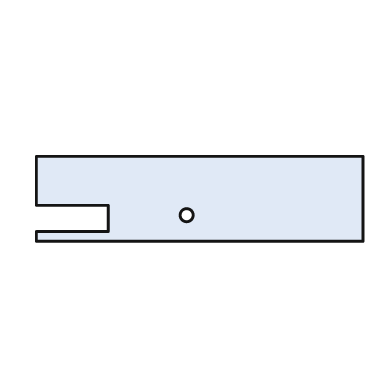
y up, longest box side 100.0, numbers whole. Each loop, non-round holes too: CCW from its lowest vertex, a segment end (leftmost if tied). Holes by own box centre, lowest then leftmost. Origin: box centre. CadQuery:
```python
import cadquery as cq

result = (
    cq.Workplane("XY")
    .moveTo(-50.0, -13.0)
    .lineTo(50.0, -13.0)
    .lineTo(50.0, 13.0)
    .lineTo(-50.0, 13.0)
    .lineTo(-50.0, -2.0)
    .lineTo(-28.0, -2.0)
    .lineTo(-28.0, -10.0)
    .lineTo(-50.0, -10.0)
    .close()
    .moveTo(-4.0, -5.0)
    .circle(2.0)
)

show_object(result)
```